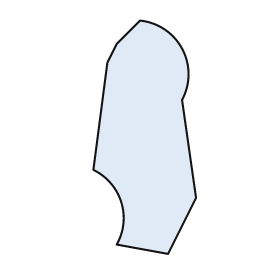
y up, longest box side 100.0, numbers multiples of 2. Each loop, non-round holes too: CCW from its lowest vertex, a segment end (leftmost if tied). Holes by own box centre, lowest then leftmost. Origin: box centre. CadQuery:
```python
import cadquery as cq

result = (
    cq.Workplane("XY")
    .moveTo(10.0, -50.0)
    .lineTo(22.0, -26.0)
    .lineTo(16.0, 16.0)
    .threePointArc((16.0, 38.0), (-2.0, 50.0))
    .lineTo(-12.0, 40.0)
    .lineTo(-16.0, 32.0)
    .lineTo(-22.0, -14.0)
    .threePointArc((-10.0, -28.0), (-12.0, -46.0))
    .close()
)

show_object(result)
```